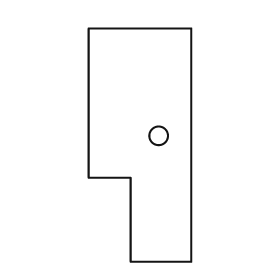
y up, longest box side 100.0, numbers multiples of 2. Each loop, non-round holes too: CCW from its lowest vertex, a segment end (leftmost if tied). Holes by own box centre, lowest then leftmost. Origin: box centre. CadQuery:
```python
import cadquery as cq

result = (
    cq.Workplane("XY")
    .moveTo(-4.0, -50.0)
    .lineTo(22.0, -50.0)
    .lineTo(22.0, 50.0)
    .lineTo(-22.0, 50.0)
    .lineTo(-22.0, -14.0)
    .lineTo(-4.0, -14.0)
    .close()
    .moveTo(8.0, 4.0)
    .circle(4.0)
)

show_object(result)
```